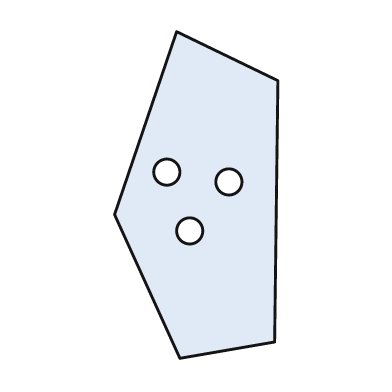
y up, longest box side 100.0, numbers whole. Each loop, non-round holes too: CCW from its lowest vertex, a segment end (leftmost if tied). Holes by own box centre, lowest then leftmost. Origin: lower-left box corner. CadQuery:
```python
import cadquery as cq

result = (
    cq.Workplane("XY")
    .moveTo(20.0, 0.0)
    .lineTo(49.0, 5.0)
    .lineTo(50.0, 85.0)
    .lineTo(19.0, 100.0)
    .lineTo(0.0, 44.0)
    .close()
    .moveTo(23.0, 39.0)
    .circle(4.0)
    .moveTo(35.0, 54.0)
    .circle(4.0)
    .moveTo(16.0, 57.0)
    .circle(4.0)
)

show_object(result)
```